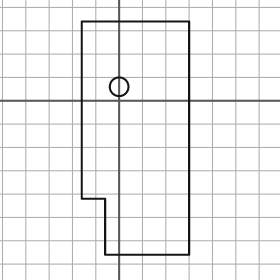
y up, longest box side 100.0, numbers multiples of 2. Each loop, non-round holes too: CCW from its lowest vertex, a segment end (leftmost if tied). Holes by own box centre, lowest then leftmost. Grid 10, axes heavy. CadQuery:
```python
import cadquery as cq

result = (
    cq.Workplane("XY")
    .moveTo(-6.0, -66.0)
    .lineTo(30.0, -66.0)
    .lineTo(30.0, 34.0)
    .lineTo(-16.0, 34.0)
    .lineTo(-16.0, -42.0)
    .lineTo(-6.0, -42.0)
    .close()
    .moveTo(0.0, 6.0)
    .circle(4.0)
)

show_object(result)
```